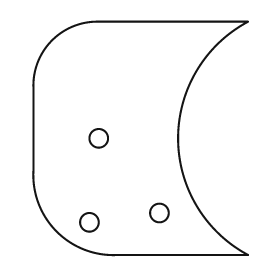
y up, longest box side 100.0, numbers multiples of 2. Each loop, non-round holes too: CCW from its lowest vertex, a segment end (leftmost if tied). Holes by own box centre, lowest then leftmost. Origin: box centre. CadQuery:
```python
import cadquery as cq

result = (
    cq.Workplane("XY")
    .moveTo(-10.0, -50.0)
    .lineTo(46.0, -50.0)
    .threePointArc((16.0, 0.0), (46.0, 50.0))
    .lineTo(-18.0, 50.0)
    .threePointArc((-38.0, 42.0), (-46.0, 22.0))
    .lineTo(-46.0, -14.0)
    .threePointArc((-36.0, -40.0), (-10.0, -50.0))
    .close()
    .moveTo(-22.0, -36.0)
    .circle(4.0)
    .moveTo(8.0, -32.0)
    .circle(4.0)
    .moveTo(-18.0, 0.0)
    .circle(4.0)
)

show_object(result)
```